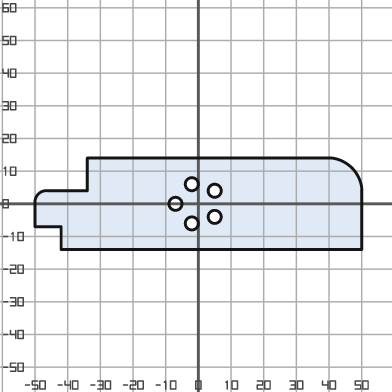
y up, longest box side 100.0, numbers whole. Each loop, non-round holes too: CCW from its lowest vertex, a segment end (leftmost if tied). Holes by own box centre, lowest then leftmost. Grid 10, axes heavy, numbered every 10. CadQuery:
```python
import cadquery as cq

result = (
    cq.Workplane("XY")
    .moveTo(-42.0, -14.0)
    .lineTo(50.0, -14.0)
    .lineTo(50.0, 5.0)
    .threePointArc((47.0, 11.0), (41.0, 14.0))
    .lineTo(-34.0, 14.0)
    .lineTo(-34.0, 4.0)
    .lineTo(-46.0, 4.0)
    .threePointArc((-49.0, 3.0), (-50.0, 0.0))
    .lineTo(-50.0, -7.0)
    .lineTo(-42.0, -7.0)
    .close()
    .moveTo(-2.0, -6.0)
    .circle(2.0)
    .moveTo(5.0, -4.0)
    .circle(2.0)
    .moveTo(-7.0, 0.0)
    .circle(2.0)
    .moveTo(5.0, 4.0)
    .circle(2.0)
    .moveTo(-2.0, 6.0)
    .circle(2.0)
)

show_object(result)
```